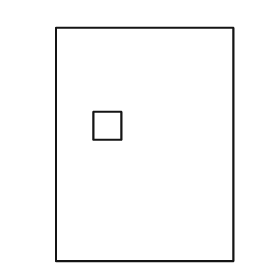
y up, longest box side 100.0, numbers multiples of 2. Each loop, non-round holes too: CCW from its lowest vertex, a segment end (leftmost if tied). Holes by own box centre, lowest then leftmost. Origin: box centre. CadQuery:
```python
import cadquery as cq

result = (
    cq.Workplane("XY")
    .moveTo(-38.0, -50.0)
    .lineTo(38.0, -50.0)
    .lineTo(38.0, 50.0)
    .lineTo(-38.0, 50.0)
    .close()
    .moveTo(-22.0, 2.0)
    .lineTo(-10.0, 2.0)
    .lineTo(-10.0, 14.0)
    .lineTo(-22.0, 14.0)
    .close()
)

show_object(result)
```